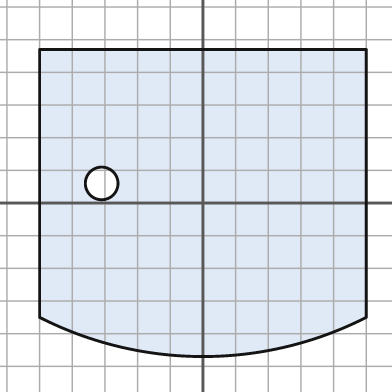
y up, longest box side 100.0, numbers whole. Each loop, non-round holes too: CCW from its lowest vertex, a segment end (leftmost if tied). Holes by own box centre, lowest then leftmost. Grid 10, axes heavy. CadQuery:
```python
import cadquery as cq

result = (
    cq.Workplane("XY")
    .moveTo(-50.0, -35.0)
    .threePointArc((0.0, -47.0), (50.0, -35.0))
    .lineTo(50.0, 47.0)
    .lineTo(-50.0, 47.0)
    .close()
    .moveTo(-31.0, 6.0)
    .circle(5.0)
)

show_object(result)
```